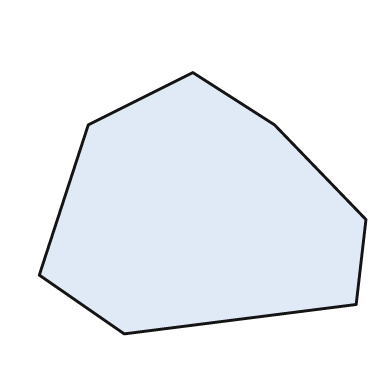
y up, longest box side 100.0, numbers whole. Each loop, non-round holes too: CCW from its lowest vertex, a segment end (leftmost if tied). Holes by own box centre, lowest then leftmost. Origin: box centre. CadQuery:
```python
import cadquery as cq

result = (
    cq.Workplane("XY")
    .moveTo(-24.0, -40.0)
    .lineTo(47.0, -31.0)
    .lineTo(50.0, -5.0)
    .lineTo(22.0, 24.0)
    .lineTo(-3.0, 40.0)
    .lineTo(-35.0, 24.0)
    .lineTo(-50.0, -22.0)
    .close()
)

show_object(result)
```